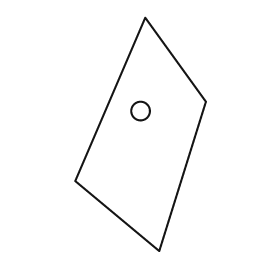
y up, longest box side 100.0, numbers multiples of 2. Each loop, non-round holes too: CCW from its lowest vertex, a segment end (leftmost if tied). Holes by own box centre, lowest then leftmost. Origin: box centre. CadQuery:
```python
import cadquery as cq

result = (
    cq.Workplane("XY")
    .moveTo(8.0, -50.0)
    .lineTo(28.0, 14.0)
    .lineTo(2.0, 50.0)
    .lineTo(-28.0, -20.0)
    .close()
    .moveTo(0.0, 10.0)
    .circle(4.0)
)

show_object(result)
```